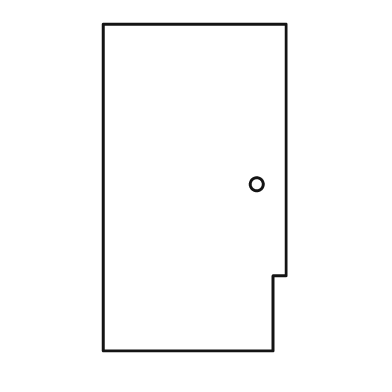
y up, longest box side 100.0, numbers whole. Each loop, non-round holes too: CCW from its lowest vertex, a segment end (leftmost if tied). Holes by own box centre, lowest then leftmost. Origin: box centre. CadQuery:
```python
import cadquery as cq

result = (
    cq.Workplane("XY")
    .moveTo(-28.0, -50.0)
    .lineTo(24.0, -50.0)
    .lineTo(24.0, -27.0)
    .lineTo(28.0, -27.0)
    .lineTo(28.0, 50.0)
    .lineTo(-28.0, 50.0)
    .close()
    .moveTo(19.0, 1.0)
    .circle(2.0)
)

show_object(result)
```